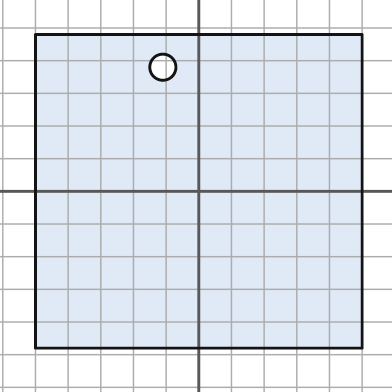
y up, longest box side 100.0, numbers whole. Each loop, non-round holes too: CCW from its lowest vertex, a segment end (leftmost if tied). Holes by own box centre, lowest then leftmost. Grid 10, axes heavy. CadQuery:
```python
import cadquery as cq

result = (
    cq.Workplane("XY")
    .moveTo(-50.0, -48.0)
    .lineTo(50.0, -48.0)
    .lineTo(50.0, 48.0)
    .lineTo(-50.0, 48.0)
    .close()
    .moveTo(-11.0, 38.0)
    .circle(4.0)
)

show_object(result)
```